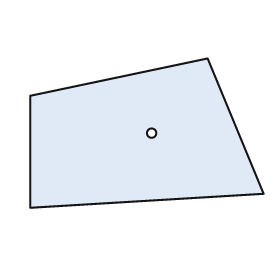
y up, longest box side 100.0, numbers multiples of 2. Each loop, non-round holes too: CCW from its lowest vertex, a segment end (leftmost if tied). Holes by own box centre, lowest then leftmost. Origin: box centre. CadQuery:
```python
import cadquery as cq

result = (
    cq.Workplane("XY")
    .moveTo(-50.0, -32.0)
    .lineTo(50.0, -26.0)
    .lineTo(26.0, 32.0)
    .lineTo(-50.0, 16.0)
    .close()
    .moveTo(2.0, 0.0)
    .circle(2.0)
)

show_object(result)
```